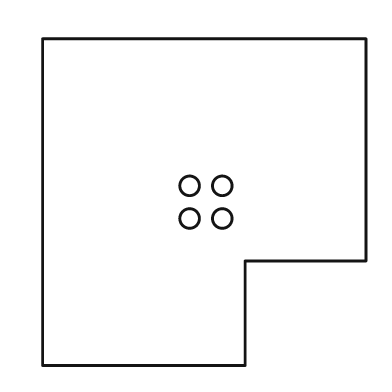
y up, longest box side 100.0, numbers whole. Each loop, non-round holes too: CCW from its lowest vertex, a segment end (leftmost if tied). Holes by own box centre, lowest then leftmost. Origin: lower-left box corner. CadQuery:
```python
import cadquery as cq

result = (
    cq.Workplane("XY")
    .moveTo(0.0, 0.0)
    .lineTo(62.0, 0.0)
    .lineTo(62.0, 32.0)
    .lineTo(99.0, 32.0)
    .lineTo(99.0, 100.0)
    .lineTo(0.0, 100.0)
    .close()
    .moveTo(45.0, 45.0)
    .circle(3.0)
    .moveTo(55.0, 45.0)
    .circle(3.0)
    .moveTo(45.0, 55.0)
    .circle(3.0)
    .moveTo(55.0, 55.0)
    .circle(3.0)
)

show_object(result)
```